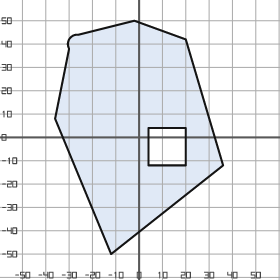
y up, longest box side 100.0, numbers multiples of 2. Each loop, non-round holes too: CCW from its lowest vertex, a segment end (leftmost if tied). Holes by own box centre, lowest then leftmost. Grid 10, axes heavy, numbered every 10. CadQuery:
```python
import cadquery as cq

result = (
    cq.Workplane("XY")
    .moveTo(-12.0, -50.0)
    .lineTo(36.0, -12.0)
    .lineTo(20.0, 42.0)
    .lineTo(-2.0, 50.0)
    .lineTo(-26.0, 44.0)
    .threePointArc((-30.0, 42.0), (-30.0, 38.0))
    .lineTo(-36.0, 8.0)
    .close()
    .moveTo(4.0, -12.0)
    .lineTo(20.0, -12.0)
    .lineTo(20.0, 4.0)
    .lineTo(4.0, 4.0)
    .close()
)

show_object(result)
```